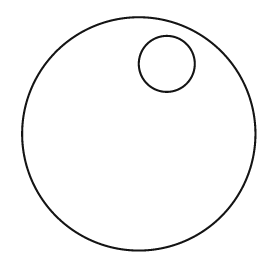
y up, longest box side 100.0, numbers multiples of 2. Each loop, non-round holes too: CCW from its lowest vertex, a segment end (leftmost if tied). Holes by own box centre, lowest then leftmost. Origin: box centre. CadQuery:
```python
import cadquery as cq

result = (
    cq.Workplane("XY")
    .moveTo(0.0, 0.0)
    .circle(50.0)
    .moveTo(12.0, 30.0)
    .circle(12.0)
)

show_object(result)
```